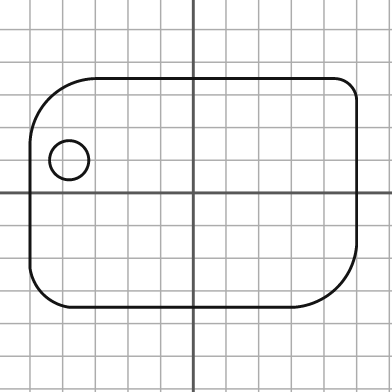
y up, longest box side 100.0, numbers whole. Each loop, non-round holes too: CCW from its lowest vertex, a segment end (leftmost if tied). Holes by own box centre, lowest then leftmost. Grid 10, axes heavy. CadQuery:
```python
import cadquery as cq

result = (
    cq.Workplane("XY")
    .moveTo(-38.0, -35.0)
    .lineTo(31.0, -35.0)
    .threePointArc((44.0, -29.0), (50.0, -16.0))
    .lineTo(50.0, 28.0)
    .threePointArc((48.0, 33.0), (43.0, 35.0))
    .lineTo(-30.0, 35.0)
    .threePointArc((-44.0, 29.0), (-50.0, 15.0))
    .lineTo(-50.0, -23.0)
    .threePointArc((-46.0, -31.0), (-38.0, -35.0))
    .close()
    .moveTo(-38.0, 10.0)
    .circle(6.0)
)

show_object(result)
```